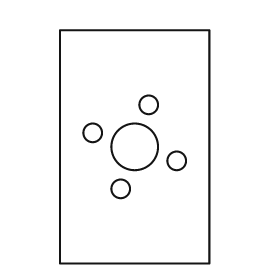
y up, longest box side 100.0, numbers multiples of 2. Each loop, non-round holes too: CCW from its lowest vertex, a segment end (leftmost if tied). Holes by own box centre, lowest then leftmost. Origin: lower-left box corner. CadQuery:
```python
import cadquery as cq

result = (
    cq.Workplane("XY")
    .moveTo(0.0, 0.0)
    .lineTo(64.0, 0.0)
    .lineTo(64.0, 100.0)
    .lineTo(0.0, 100.0)
    .close()
    .moveTo(26.0, 32.0)
    .circle(4.0)
    .moveTo(50.0, 44.0)
    .circle(4.0)
    .moveTo(32.0, 50.0)
    .circle(10.0)
    .moveTo(14.0, 56.0)
    .circle(4.0)
    .moveTo(38.0, 68.0)
    .circle(4.0)
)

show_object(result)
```